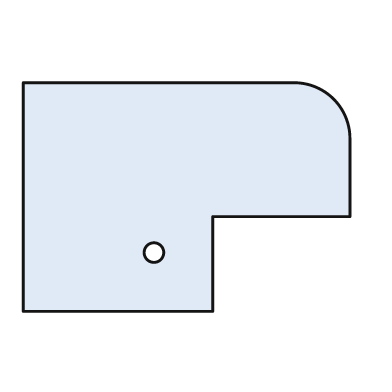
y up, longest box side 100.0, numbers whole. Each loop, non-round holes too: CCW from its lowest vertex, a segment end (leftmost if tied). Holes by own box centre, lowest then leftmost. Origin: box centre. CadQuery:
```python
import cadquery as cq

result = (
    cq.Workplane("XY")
    .moveTo(-50.0, -35.0)
    .lineTo(8.0, -35.0)
    .lineTo(8.0, -6.0)
    .lineTo(50.0, -6.0)
    .lineTo(50.0, 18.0)
    .threePointArc((45.0, 30.0), (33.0, 35.0))
    .lineTo(-50.0, 35.0)
    .close()
    .moveTo(-10.0, -17.0)
    .circle(3.0)
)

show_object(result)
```